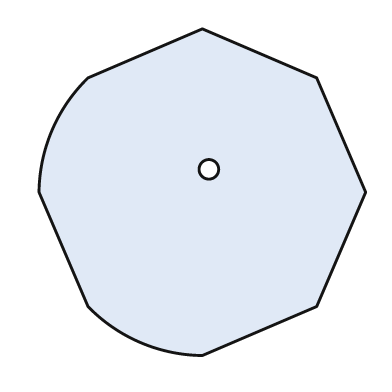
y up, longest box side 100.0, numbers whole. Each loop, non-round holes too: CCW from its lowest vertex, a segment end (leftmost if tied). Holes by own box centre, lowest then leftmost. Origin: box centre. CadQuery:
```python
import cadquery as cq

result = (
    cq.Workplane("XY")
    .moveTo(0.0, -50.0)
    .lineTo(35.0, -35.0)
    .lineTo(50.0, 0.0)
    .lineTo(35.0, 35.0)
    .lineTo(0.0, 50.0)
    .lineTo(-35.0, 35.0)
    .threePointArc((-46.0, 19.0), (-50.0, 0.0))
    .lineTo(-35.0, -35.0)
    .threePointArc((-19.0, -46.0), (0.0, -50.0))
    .close()
    .moveTo(2.0, 7.0)
    .circle(3.0)
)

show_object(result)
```